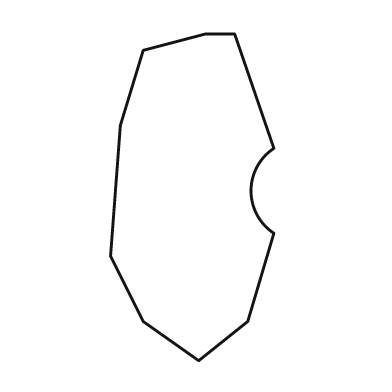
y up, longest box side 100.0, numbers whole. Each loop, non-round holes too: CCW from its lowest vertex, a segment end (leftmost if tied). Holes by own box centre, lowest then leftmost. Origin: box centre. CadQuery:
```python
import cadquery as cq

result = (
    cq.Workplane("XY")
    .moveTo(2.0, -50.0)
    .lineTo(17.0, -38.0)
    .lineTo(25.0, -11.0)
    .threePointArc((18.0, 2.0), (25.0, 15.0))
    .lineTo(13.0, 50.0)
    .lineTo(4.0, 50.0)
    .lineTo(-15.0, 45.0)
    .lineTo(-22.0, 22.0)
    .lineTo(-25.0, -18.0)
    .lineTo(-15.0, -38.0)
    .close()
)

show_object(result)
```